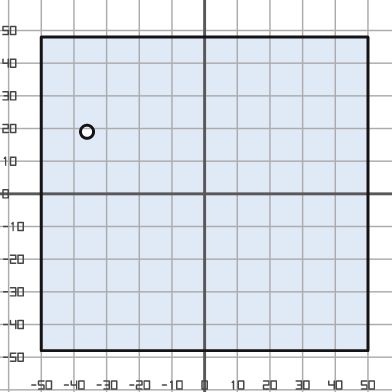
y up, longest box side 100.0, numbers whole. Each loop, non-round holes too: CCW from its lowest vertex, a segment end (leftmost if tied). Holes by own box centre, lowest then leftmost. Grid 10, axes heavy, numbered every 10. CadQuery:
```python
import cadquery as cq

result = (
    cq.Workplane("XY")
    .moveTo(-50.0, -48.0)
    .lineTo(50.0, -48.0)
    .lineTo(50.0, 48.0)
    .lineTo(-50.0, 48.0)
    .close()
    .moveTo(-36.0, 19.0)
    .circle(2.0)
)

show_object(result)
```